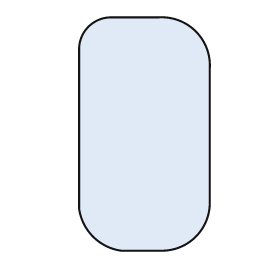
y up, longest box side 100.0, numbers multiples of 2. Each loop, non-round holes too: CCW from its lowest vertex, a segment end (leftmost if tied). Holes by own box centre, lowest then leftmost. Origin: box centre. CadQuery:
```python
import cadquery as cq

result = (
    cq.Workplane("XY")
    .moveTo(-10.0, -50.0)
    .lineTo(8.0, -50.0)
    .threePointArc((22.0, -44.0), (28.0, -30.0))
    .lineTo(28.0, 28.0)
    .threePointArc((22.0, 44.0), (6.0, 50.0))
    .lineTo(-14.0, 50.0)
    .threePointArc((-24.0, 46.0), (-28.0, 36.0))
    .lineTo(-28.0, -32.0)
    .threePointArc((-22.0, -44.0), (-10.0, -50.0))
    .close()
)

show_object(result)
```